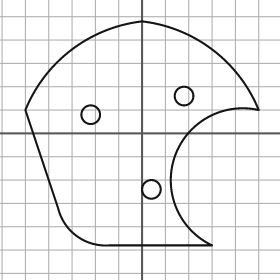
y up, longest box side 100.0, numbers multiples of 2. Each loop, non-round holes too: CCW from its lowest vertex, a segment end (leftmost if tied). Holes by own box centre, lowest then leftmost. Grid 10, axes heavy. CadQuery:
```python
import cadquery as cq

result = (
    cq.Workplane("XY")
    .moveTo(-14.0, -48.0)
    .lineTo(30.0, -48.0)
    .threePointArc((14.0, -10.0), (50.0, 10.0))
    .threePointArc((30.0, 36.0), (0.0, 48.0))
    .threePointArc((-30.0, 36.0), (-50.0, 10.0))
    .lineTo(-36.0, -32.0)
    .threePointArc((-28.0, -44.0), (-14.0, -48.0))
    .close()
    .moveTo(4.0, -24.0)
    .circle(4.0)
    .moveTo(-22.0, 8.0)
    .circle(4.0)
    .moveTo(18.0, 16.0)
    .circle(4.0)
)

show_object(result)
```